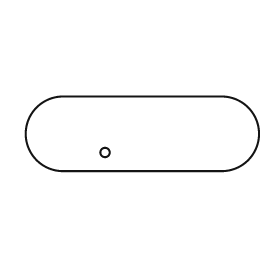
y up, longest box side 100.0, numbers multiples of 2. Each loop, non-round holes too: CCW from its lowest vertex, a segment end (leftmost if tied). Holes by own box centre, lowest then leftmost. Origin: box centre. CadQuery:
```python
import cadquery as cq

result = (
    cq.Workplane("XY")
    .moveTo(-34.0, -16.0)
    .lineTo(34.0, -16.0)
    .threePointArc((50.0, 0.0), (34.0, 16.0))
    .lineTo(-34.0, 16.0)
    .threePointArc((-50.0, 0.0), (-34.0, -16.0))
    .close()
    .moveTo(-16.0, -8.0)
    .circle(2.0)
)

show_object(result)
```